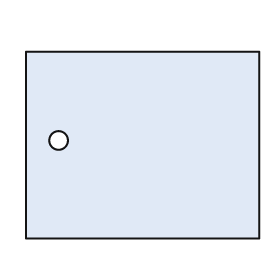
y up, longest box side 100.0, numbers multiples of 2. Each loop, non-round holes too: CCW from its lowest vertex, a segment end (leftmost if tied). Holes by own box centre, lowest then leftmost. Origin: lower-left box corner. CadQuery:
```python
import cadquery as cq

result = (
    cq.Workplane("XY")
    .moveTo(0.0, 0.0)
    .lineTo(100.0, 0.0)
    .lineTo(100.0, 80.0)
    .lineTo(0.0, 80.0)
    .close()
    .moveTo(14.0, 42.0)
    .circle(4.0)
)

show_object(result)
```